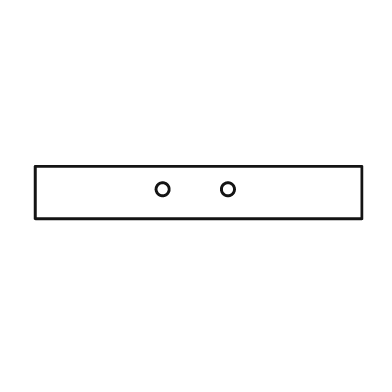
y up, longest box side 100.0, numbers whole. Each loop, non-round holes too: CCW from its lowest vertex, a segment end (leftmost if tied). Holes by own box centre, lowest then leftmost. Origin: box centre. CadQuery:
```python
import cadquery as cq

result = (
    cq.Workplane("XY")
    .moveTo(-50.0, -8.0)
    .lineTo(50.0, -8.0)
    .lineTo(50.0, 8.0)
    .lineTo(-50.0, 8.0)
    .close()
    .moveTo(-11.0, 1.0)
    .circle(2.0)
    .moveTo(9.0, 1.0)
    .circle(2.0)
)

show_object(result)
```